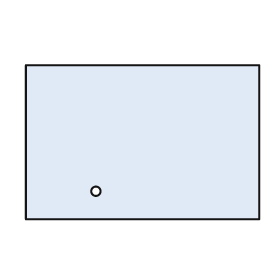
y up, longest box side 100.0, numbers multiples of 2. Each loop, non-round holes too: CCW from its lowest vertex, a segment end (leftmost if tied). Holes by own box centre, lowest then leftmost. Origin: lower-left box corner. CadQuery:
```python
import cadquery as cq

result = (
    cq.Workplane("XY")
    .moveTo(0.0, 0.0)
    .lineTo(100.0, 0.0)
    .lineTo(100.0, 66.0)
    .lineTo(0.0, 66.0)
    .close()
    .moveTo(30.0, 12.0)
    .circle(2.0)
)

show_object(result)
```